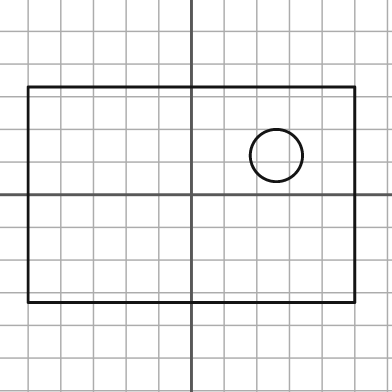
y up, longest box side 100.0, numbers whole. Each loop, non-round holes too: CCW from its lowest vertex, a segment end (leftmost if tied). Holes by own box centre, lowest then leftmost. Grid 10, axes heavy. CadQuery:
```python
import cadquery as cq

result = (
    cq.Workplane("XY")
    .moveTo(-50.0, -33.0)
    .lineTo(50.0, -33.0)
    .lineTo(50.0, 33.0)
    .lineTo(-50.0, 33.0)
    .close()
    .moveTo(26.0, 12.0)
    .circle(8.0)
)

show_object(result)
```